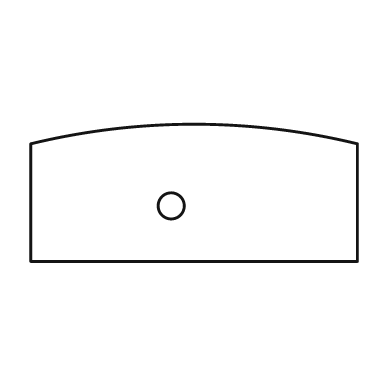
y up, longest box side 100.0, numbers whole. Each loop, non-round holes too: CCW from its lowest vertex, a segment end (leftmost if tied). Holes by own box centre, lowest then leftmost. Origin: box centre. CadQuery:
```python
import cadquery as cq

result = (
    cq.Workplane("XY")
    .moveTo(-50.0, -21.0)
    .lineTo(50.0, -21.0)
    .lineTo(50.0, 15.0)
    .threePointArc((0.0, 21.0), (-50.0, 15.0))
    .close()
    .moveTo(-7.0, -4.0)
    .circle(4.0)
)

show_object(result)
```